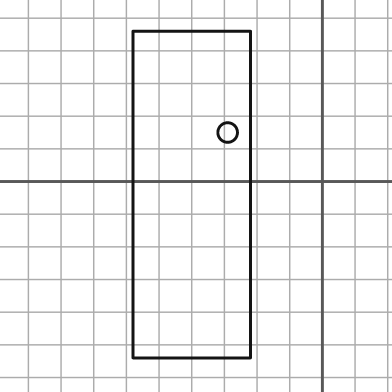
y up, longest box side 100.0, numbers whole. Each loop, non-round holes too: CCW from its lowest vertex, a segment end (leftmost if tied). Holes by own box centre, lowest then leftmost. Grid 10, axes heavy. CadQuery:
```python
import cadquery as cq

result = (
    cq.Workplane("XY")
    .moveTo(-58.0, -54.0)
    .lineTo(-22.0, -54.0)
    .lineTo(-22.0, 46.0)
    .lineTo(-58.0, 46.0)
    .close()
    .moveTo(-29.0, 15.0)
    .circle(3.0)
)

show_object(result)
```